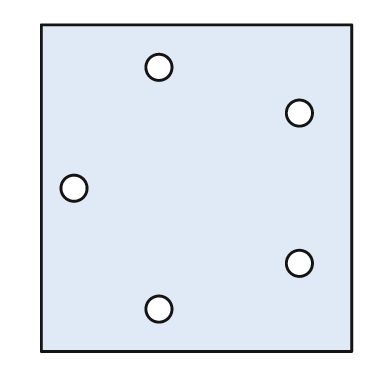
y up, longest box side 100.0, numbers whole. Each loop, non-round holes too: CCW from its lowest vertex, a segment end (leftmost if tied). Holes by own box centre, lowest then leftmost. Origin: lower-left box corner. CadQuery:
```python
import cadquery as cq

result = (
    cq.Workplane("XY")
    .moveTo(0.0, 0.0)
    .lineTo(95.0, 0.0)
    .lineTo(95.0, 100.0)
    .lineTo(0.0, 100.0)
    .close()
    .moveTo(36.0, 13.0)
    .circle(4.0)
    .moveTo(79.0, 27.0)
    .circle(4.0)
    .moveTo(10.0, 50.0)
    .circle(4.0)
    .moveTo(79.0, 73.0)
    .circle(4.0)
    .moveTo(36.0, 87.0)
    .circle(4.0)
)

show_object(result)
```